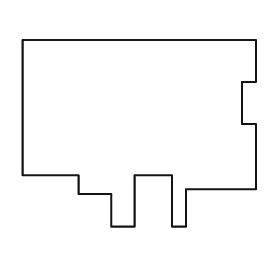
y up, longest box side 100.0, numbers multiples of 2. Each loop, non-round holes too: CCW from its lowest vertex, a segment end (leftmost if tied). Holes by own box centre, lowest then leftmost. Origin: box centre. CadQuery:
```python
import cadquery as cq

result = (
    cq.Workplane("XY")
    .moveTo(-12.0, -40.0)
    .lineTo(-2.0, -40.0)
    .lineTo(-2.0, -18.0)
    .lineTo(14.0, -18.0)
    .lineTo(14.0, -40.0)
    .lineTo(20.0, -40.0)
    .lineTo(20.0, -24.0)
    .lineTo(50.0, -24.0)
    .lineTo(50.0, 4.0)
    .lineTo(44.0, 4.0)
    .lineTo(44.0, 22.0)
    .lineTo(50.0, 22.0)
    .lineTo(50.0, 40.0)
    .lineTo(-50.0, 40.0)
    .lineTo(-50.0, -18.0)
    .lineTo(-26.0, -18.0)
    .lineTo(-26.0, -26.0)
    .lineTo(-12.0, -26.0)
    .close()
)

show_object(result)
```